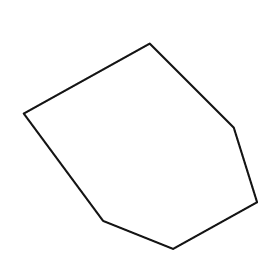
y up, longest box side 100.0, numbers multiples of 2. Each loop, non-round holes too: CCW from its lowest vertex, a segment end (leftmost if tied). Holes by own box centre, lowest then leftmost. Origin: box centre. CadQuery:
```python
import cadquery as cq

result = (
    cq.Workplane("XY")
    .moveTo(14.0, -44.0)
    .lineTo(50.0, -24.0)
    .lineTo(40.0, 8.0)
    .lineTo(4.0, 44.0)
    .lineTo(-50.0, 14.0)
    .lineTo(-16.0, -32.0)
    .close()
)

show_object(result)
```